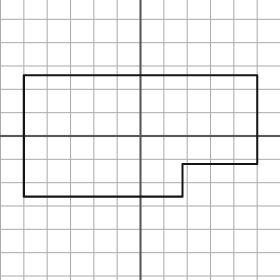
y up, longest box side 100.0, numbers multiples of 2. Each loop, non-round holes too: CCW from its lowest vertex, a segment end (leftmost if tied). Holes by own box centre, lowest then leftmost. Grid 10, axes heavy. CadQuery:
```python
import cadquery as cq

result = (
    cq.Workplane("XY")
    .moveTo(-50.0, -26.0)
    .lineTo(18.0, -26.0)
    .lineTo(18.0, -12.0)
    .lineTo(50.0, -12.0)
    .lineTo(50.0, 26.0)
    .lineTo(-50.0, 26.0)
    .close()
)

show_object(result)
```